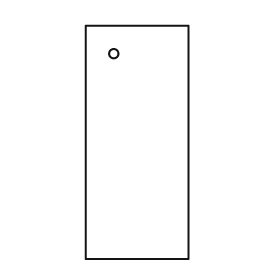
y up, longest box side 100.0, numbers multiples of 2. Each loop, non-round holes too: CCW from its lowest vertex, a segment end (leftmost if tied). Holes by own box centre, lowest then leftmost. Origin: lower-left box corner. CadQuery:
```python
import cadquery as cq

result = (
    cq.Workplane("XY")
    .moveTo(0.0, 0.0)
    .lineTo(44.0, 0.0)
    .lineTo(44.0, 100.0)
    .lineTo(0.0, 100.0)
    .close()
    .moveTo(12.0, 88.0)
    .circle(2.0)
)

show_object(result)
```